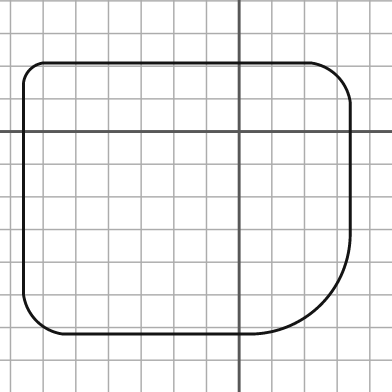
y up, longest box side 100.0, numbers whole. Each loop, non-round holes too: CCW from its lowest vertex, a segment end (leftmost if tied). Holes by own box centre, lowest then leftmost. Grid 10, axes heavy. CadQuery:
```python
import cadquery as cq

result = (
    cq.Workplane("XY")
    .moveTo(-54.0, -62.0)
    .lineTo(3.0, -62.0)
    .threePointArc((25.0, -53.0), (34.0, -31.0))
    .lineTo(34.0, 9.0)
    .threePointArc((30.0, 17.0), (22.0, 21.0))
    .lineTo(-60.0, 21.0)
    .threePointArc((-64.0, 19.0), (-66.0, 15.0))
    .lineTo(-66.0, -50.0)
    .threePointArc((-62.0, -58.0), (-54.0, -62.0))
    .close()
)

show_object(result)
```